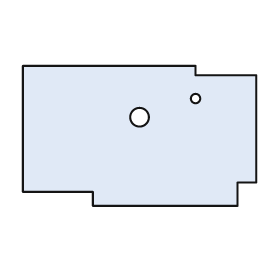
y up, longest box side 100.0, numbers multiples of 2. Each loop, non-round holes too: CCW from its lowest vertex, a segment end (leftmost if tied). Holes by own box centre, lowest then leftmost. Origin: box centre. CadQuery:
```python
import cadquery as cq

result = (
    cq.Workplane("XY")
    .moveTo(-20.0, -30.0)
    .lineTo(42.0, -30.0)
    .lineTo(42.0, -20.0)
    .lineTo(50.0, -20.0)
    .lineTo(50.0, 26.0)
    .lineTo(24.0, 26.0)
    .lineTo(24.0, 30.0)
    .lineTo(-50.0, 30.0)
    .lineTo(-50.0, -24.0)
    .lineTo(-20.0, -24.0)
    .close()
    .moveTo(0.0, 8.0)
    .circle(4.0)
    .moveTo(24.0, 16.0)
    .circle(2.0)
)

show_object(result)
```